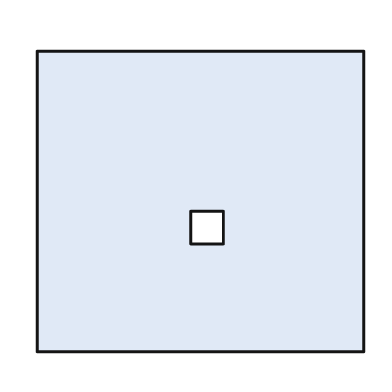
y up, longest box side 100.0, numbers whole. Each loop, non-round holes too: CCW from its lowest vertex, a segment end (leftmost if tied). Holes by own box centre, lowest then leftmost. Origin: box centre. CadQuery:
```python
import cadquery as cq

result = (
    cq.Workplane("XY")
    .moveTo(-50.0, -46.0)
    .lineTo(50.0, -46.0)
    .lineTo(50.0, 46.0)
    .lineTo(-50.0, 46.0)
    .close()
    .moveTo(-3.0, -13.0)
    .lineTo(7.0, -13.0)
    .lineTo(7.0, -3.0)
    .lineTo(-3.0, -3.0)
    .close()
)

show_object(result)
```